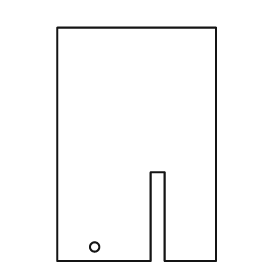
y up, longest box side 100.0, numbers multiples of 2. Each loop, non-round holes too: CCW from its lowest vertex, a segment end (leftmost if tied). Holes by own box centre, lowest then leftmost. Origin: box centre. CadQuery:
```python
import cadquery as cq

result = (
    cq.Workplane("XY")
    .moveTo(-34.0, -50.0)
    .lineTo(6.0, -50.0)
    .lineTo(6.0, -12.0)
    .lineTo(12.0, -12.0)
    .lineTo(12.0, -50.0)
    .lineTo(34.0, -50.0)
    .lineTo(34.0, 50.0)
    .lineTo(-34.0, 50.0)
    .close()
    .moveTo(-18.0, -44.0)
    .circle(2.0)
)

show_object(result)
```